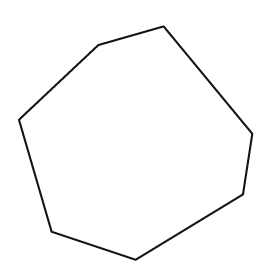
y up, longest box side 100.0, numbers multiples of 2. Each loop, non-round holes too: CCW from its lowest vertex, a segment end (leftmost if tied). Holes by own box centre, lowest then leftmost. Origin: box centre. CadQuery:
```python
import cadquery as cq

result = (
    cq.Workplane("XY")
    .moveTo(0.0, -50.0)
    .lineTo(46.0, -22.0)
    .lineTo(50.0, 4.0)
    .lineTo(12.0, 50.0)
    .lineTo(-16.0, 42.0)
    .lineTo(-50.0, 10.0)
    .lineTo(-36.0, -38.0)
    .close()
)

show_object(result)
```